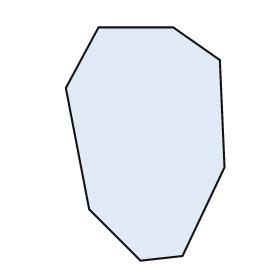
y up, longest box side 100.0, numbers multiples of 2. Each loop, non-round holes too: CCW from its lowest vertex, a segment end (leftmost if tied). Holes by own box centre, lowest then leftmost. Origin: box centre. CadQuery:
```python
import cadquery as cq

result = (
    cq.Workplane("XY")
    .moveTo(-2.0, -50.0)
    .lineTo(16.0, -48.0)
    .lineTo(34.0, -10.0)
    .lineTo(32.0, 36.0)
    .lineTo(12.0, 50.0)
    .lineTo(-20.0, 50.0)
    .lineTo(-34.0, 24.0)
    .lineTo(-24.0, -28.0)
    .close()
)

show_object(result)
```